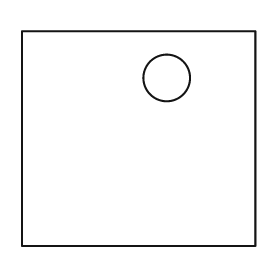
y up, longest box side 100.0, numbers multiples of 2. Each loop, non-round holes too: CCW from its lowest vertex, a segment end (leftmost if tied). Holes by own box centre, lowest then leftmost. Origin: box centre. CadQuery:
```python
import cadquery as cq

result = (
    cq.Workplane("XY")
    .moveTo(-50.0, -46.0)
    .lineTo(50.0, -46.0)
    .lineTo(50.0, 46.0)
    .lineTo(-50.0, 46.0)
    .close()
    .moveTo(12.0, 26.0)
    .circle(10.0)
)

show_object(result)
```